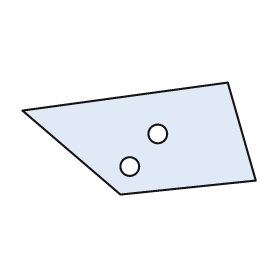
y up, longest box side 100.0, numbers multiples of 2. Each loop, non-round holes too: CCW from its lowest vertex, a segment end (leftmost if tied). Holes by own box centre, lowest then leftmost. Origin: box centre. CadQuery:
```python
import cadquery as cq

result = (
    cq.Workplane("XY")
    .moveTo(-8.0, -24.0)
    .lineTo(50.0, -18.0)
    .lineTo(38.0, 24.0)
    .lineTo(-50.0, 12.0)
    .close()
    .moveTo(-4.0, -12.0)
    .circle(4.0)
    .moveTo(8.0, 2.0)
    .circle(4.0)
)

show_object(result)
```